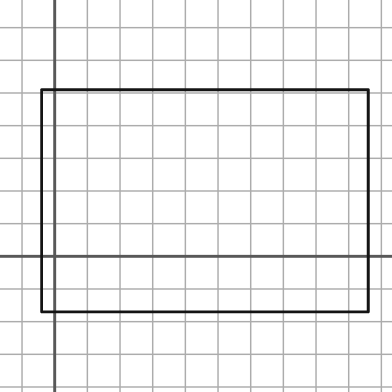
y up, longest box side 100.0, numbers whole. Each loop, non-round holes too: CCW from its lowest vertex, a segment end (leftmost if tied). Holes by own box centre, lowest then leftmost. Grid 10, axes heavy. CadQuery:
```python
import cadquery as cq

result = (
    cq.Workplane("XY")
    .moveTo(-4.0, -17.0)
    .lineTo(96.0, -17.0)
    .lineTo(96.0, 51.0)
    .lineTo(-4.0, 51.0)
    .close()
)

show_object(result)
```